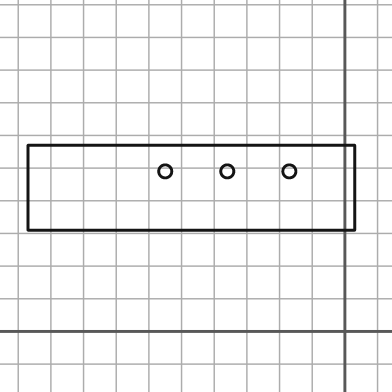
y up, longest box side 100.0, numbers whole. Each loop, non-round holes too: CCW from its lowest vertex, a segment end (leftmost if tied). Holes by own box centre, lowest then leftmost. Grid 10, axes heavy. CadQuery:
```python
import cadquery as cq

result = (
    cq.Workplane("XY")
    .moveTo(-97.0, 31.0)
    .lineTo(3.0, 31.0)
    .lineTo(3.0, 57.0)
    .lineTo(-97.0, 57.0)
    .close()
    .moveTo(-55.0, 49.0)
    .circle(2.0)
    .moveTo(-36.0, 49.0)
    .circle(2.0)
    .moveTo(-17.0, 49.0)
    .circle(2.0)
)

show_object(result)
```